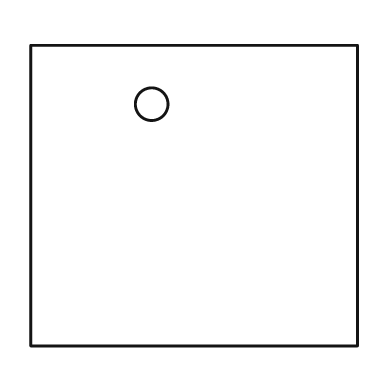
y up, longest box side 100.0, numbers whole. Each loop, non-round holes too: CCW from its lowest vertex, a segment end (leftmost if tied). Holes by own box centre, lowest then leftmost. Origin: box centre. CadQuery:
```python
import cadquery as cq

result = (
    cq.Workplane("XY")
    .moveTo(-50.0, -46.0)
    .lineTo(50.0, -46.0)
    .lineTo(50.0, 46.0)
    .lineTo(-50.0, 46.0)
    .close()
    .moveTo(-13.0, 28.0)
    .circle(5.0)
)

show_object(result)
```